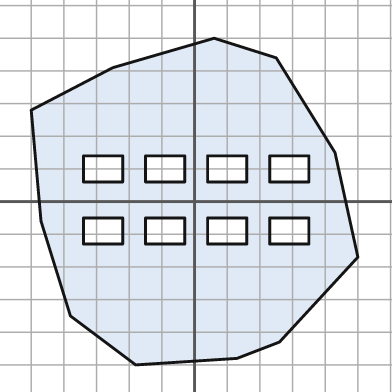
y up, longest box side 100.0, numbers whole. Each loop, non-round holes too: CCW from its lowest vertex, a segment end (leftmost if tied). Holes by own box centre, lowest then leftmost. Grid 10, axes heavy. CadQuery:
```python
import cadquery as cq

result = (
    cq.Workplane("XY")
    .moveTo(-18.0, -50.0)
    .lineTo(13.0, -48.0)
    .lineTo(26.0, -43.0)
    .lineTo(50.0, -17.0)
    .lineTo(43.0, 15.0)
    .lineTo(25.0, 44.0)
    .lineTo(6.0, 50.0)
    .lineTo(-25.0, 41.0)
    .lineTo(-50.0, 28.0)
    .lineTo(-47.0, -6.0)
    .lineTo(-38.0, -35.0)
    .close()
    .moveTo(-34.0, -13.0)
    .lineTo(-22.0, -13.0)
    .lineTo(-22.0, -5.0)
    .lineTo(-34.0, -5.0)
    .close()
    .moveTo(-15.0, -13.0)
    .lineTo(-3.0, -13.0)
    .lineTo(-3.0, -5.0)
    .lineTo(-15.0, -5.0)
    .close()
    .moveTo(4.0, -13.0)
    .lineTo(16.0, -13.0)
    .lineTo(16.0, -5.0)
    .lineTo(4.0, -5.0)
    .close()
    .moveTo(23.0, -13.0)
    .lineTo(35.0, -13.0)
    .lineTo(35.0, -5.0)
    .lineTo(23.0, -5.0)
    .close()
    .moveTo(-34.0, 6.0)
    .lineTo(-22.0, 6.0)
    .lineTo(-22.0, 14.0)
    .lineTo(-34.0, 14.0)
    .close()
    .moveTo(-15.0, 6.0)
    .lineTo(-3.0, 6.0)
    .lineTo(-3.0, 14.0)
    .lineTo(-15.0, 14.0)
    .close()
    .moveTo(4.0, 6.0)
    .lineTo(16.0, 6.0)
    .lineTo(16.0, 14.0)
    .lineTo(4.0, 14.0)
    .close()
    .moveTo(23.0, 6.0)
    .lineTo(35.0, 6.0)
    .lineTo(35.0, 14.0)
    .lineTo(23.0, 14.0)
    .close()
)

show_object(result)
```